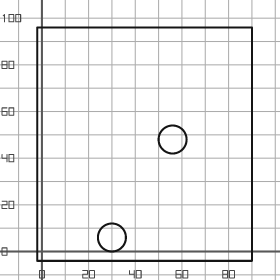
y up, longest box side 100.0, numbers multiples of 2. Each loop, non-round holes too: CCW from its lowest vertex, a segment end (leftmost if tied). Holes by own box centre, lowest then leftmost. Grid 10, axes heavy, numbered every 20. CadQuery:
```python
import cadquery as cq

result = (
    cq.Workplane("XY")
    .moveTo(-2.0, -4.0)
    .lineTo(90.0, -4.0)
    .lineTo(90.0, 96.0)
    .lineTo(-2.0, 96.0)
    .close()
    .moveTo(30.0, 6.0)
    .circle(6.0)
    .moveTo(56.0, 48.0)
    .circle(6.0)
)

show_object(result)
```